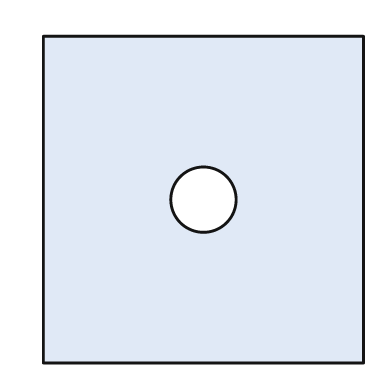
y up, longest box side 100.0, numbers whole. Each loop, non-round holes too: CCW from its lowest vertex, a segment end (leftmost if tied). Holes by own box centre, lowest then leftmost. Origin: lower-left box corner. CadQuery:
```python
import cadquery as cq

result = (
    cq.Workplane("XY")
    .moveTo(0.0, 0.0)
    .lineTo(98.0, 0.0)
    .lineTo(98.0, 100.0)
    .lineTo(0.0, 100.0)
    .close()
    .moveTo(49.0, 50.0)
    .circle(10.0)
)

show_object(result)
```